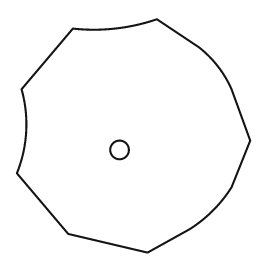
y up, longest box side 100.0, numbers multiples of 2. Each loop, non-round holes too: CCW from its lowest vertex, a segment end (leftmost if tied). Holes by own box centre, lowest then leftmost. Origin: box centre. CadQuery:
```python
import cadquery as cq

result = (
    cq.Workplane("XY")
    .moveTo(6.0, -50.0)
    .lineTo(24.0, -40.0)
    .threePointArc((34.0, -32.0), (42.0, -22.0))
    .lineTo(50.0, -2.0)
    .lineTo(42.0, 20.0)
    .threePointArc((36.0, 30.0), (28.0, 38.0))
    .lineTo(10.0, 50.0)
    .threePointArc((-8.0, 46.0), (-26.0, 46.0))
    .lineTo(-48.0, 20.0)
    .threePointArc((-46.0, 2.0), (-50.0, -16.0))
    .lineTo(-28.0, -42.0)
    .close()
    .moveTo(-6.0, -6.0)
    .circle(4.0)
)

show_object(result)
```